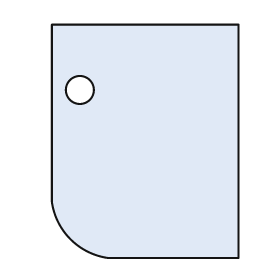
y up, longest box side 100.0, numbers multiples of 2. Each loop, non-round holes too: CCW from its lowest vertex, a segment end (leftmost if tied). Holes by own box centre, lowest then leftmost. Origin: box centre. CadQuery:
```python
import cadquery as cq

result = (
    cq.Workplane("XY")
    .moveTo(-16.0, -50.0)
    .lineTo(40.0, -50.0)
    .lineTo(40.0, 50.0)
    .lineTo(-40.0, 50.0)
    .lineTo(-40.0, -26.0)
    .threePointArc((-32.0, -42.0), (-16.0, -50.0))
    .close()
    .moveTo(-28.0, 22.0)
    .circle(6.0)
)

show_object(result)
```